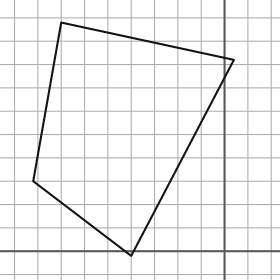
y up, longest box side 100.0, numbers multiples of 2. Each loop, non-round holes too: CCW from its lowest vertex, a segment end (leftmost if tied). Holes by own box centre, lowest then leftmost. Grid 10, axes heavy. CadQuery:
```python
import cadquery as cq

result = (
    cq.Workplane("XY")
    .moveTo(-40.0, -2.0)
    .lineTo(4.0, 82.0)
    .lineTo(-70.0, 98.0)
    .lineTo(-82.0, 30.0)
    .close()
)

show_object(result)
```